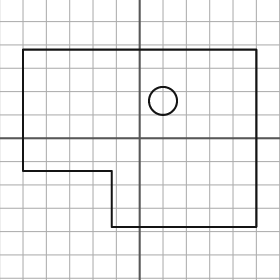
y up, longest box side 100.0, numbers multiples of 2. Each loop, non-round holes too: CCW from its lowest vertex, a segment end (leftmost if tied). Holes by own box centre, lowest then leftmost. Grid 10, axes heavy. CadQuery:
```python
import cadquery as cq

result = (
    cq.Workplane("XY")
    .moveTo(-12.0, -38.0)
    .lineTo(50.0, -38.0)
    .lineTo(50.0, 38.0)
    .lineTo(-50.0, 38.0)
    .lineTo(-50.0, -14.0)
    .lineTo(-12.0, -14.0)
    .close()
    .moveTo(10.0, 16.0)
    .circle(6.0)
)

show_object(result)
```